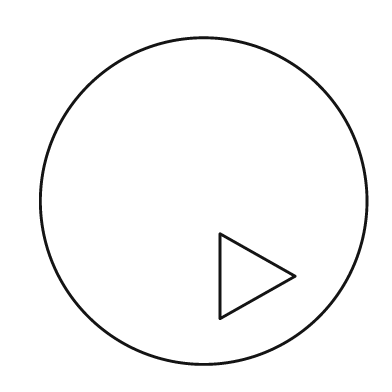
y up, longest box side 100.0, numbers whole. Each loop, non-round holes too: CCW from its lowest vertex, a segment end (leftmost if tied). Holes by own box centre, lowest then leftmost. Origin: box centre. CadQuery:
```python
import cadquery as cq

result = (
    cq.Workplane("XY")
    .moveTo(0.0, 0.0)
    .circle(50.0)
    .moveTo(5.0, -36.0)
    .lineTo(28.0, -23.0)
    .lineTo(5.0, -10.0)
    .close()
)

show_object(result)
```